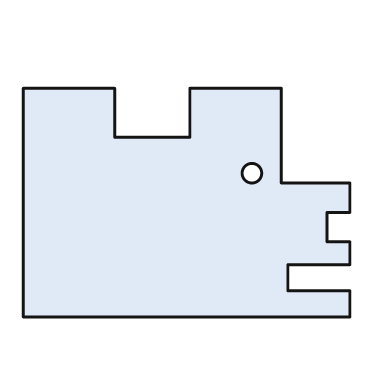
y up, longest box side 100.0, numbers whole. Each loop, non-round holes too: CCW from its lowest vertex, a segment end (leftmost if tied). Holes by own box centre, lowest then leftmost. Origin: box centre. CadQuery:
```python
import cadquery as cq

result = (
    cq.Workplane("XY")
    .moveTo(-50.0, -35.0)
    .lineTo(50.0, -35.0)
    .lineTo(50.0, -27.0)
    .lineTo(31.0, -27.0)
    .lineTo(31.0, -19.0)
    .lineTo(50.0, -19.0)
    .lineTo(50.0, -12.0)
    .lineTo(43.0, -12.0)
    .lineTo(43.0, -3.0)
    .lineTo(50.0, -3.0)
    .lineTo(50.0, 6.0)
    .lineTo(29.0, 6.0)
    .lineTo(29.0, 35.0)
    .lineTo(1.0, 35.0)
    .lineTo(1.0, 20.0)
    .lineTo(-22.0, 20.0)
    .lineTo(-22.0, 35.0)
    .lineTo(-50.0, 35.0)
    .close()
    .moveTo(20.0, 9.0)
    .circle(3.0)
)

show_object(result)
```